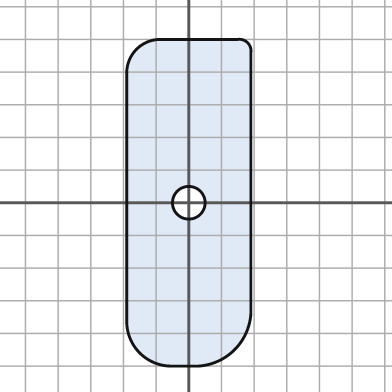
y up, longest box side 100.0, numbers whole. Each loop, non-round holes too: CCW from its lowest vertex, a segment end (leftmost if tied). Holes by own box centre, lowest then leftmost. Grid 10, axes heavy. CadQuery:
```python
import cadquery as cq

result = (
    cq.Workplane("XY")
    .moveTo(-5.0, -50.0)
    .lineTo(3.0, -50.0)
    .threePointArc((14.0, -45.0), (19.0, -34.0))
    .lineTo(19.0, 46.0)
    .threePointArc((18.0, 49.0), (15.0, 50.0))
    .lineTo(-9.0, 50.0)
    .threePointArc((-16.0, 47.0), (-19.0, 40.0))
    .lineTo(-19.0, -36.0)
    .threePointArc((-15.0, -46.0), (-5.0, -50.0))
    .close()
    .moveTo(0.0, 0.0)
    .circle(5.0)
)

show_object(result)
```